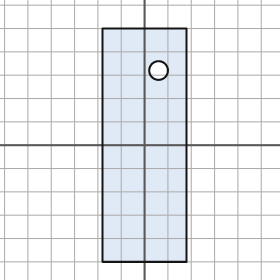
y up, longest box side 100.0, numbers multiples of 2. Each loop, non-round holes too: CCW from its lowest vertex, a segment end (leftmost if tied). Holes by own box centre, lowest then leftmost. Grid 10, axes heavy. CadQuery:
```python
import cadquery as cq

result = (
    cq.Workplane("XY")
    .moveTo(-18.0, -50.0)
    .lineTo(18.0, -50.0)
    .lineTo(18.0, 50.0)
    .lineTo(-18.0, 50.0)
    .close()
    .moveTo(6.0, 32.0)
    .circle(4.0)
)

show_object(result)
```